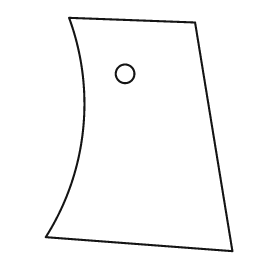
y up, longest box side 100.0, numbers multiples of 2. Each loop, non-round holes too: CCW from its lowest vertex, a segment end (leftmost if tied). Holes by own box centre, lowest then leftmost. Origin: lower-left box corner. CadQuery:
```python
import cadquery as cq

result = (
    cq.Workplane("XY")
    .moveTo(80.0, 0.0)
    .lineTo(64.0, 98.0)
    .lineTo(10.0, 100.0)
    .threePointArc((16.0, 52.0), (0.0, 6.0))
    .close()
    .moveTo(34.0, 76.0)
    .circle(4.0)
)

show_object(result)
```